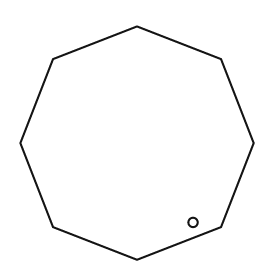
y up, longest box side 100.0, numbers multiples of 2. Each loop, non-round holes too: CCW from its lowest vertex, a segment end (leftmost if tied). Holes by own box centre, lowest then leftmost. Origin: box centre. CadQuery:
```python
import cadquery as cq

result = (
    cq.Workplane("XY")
    .moveTo(0.0, -50.0)
    .lineTo(36.0, -36.0)
    .lineTo(50.0, 0.0)
    .lineTo(36.0, 36.0)
    .lineTo(0.0, 50.0)
    .lineTo(-36.0, 36.0)
    .lineTo(-50.0, 0.0)
    .lineTo(-36.0, -36.0)
    .close()
    .moveTo(24.0, -34.0)
    .circle(2.0)
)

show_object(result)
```